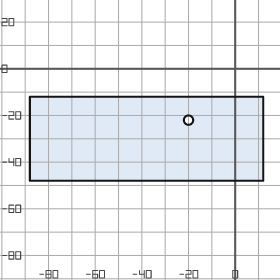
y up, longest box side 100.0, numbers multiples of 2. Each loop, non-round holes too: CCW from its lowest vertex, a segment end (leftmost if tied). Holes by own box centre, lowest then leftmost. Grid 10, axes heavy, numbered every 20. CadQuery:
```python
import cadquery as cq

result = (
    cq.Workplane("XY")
    .moveTo(-88.0, -48.0)
    .lineTo(12.0, -48.0)
    .lineTo(12.0, -12.0)
    .lineTo(-88.0, -12.0)
    .close()
    .moveTo(-20.0, -22.0)
    .circle(2.0)
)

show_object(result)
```